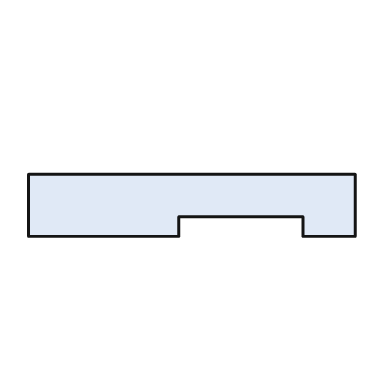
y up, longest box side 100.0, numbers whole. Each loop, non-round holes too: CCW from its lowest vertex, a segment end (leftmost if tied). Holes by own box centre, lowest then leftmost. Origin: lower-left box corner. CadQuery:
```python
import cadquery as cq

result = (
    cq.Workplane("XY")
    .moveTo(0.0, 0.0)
    .lineTo(46.0, 0.0)
    .lineTo(46.0, 6.0)
    .lineTo(84.0, 6.0)
    .lineTo(84.0, 0.0)
    .lineTo(100.0, 0.0)
    .lineTo(100.0, 19.0)
    .lineTo(0.0, 19.0)
    .close()
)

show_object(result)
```